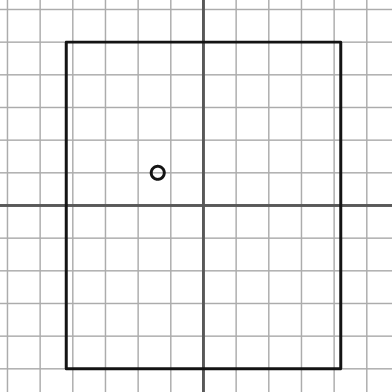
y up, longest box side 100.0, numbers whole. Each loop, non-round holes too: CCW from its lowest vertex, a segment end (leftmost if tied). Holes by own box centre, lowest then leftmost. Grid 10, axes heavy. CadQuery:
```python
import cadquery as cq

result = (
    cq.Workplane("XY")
    .moveTo(-42.0, -50.0)
    .lineTo(42.0, -50.0)
    .lineTo(42.0, 50.0)
    .lineTo(-42.0, 50.0)
    .close()
    .moveTo(-14.0, 10.0)
    .circle(2.0)
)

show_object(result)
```